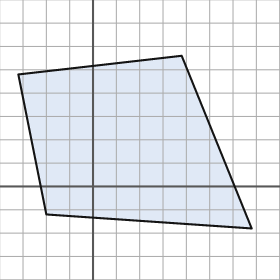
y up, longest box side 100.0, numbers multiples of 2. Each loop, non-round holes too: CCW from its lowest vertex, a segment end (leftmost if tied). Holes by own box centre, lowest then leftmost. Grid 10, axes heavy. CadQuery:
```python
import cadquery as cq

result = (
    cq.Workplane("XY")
    .moveTo(68.0, -18.0)
    .lineTo(38.0, 56.0)
    .lineTo(-32.0, 48.0)
    .lineTo(-20.0, -12.0)
    .close()
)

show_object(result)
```